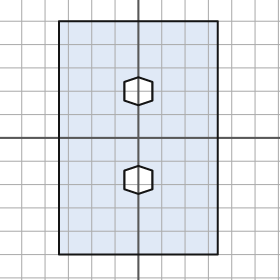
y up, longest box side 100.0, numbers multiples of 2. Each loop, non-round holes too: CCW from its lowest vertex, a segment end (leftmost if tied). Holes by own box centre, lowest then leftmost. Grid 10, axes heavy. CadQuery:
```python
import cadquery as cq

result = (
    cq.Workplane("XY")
    .moveTo(-34.0, -50.0)
    .lineTo(34.0, -50.0)
    .lineTo(34.0, 50.0)
    .lineTo(-34.0, 50.0)
    .close()
    .moveTo(0.0, -24.0)
    .lineTo(6.0, -22.0)
    .lineTo(6.0, -14.0)
    .lineTo(0.0, -12.0)
    .lineTo(-6.0, -14.0)
    .lineTo(-6.0, -22.0)
    .close()
    .moveTo(0.0, 14.0)
    .lineTo(6.0, 16.0)
    .lineTo(6.0, 24.0)
    .lineTo(0.0, 26.0)
    .lineTo(-6.0, 24.0)
    .lineTo(-6.0, 16.0)
    .close()
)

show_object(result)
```